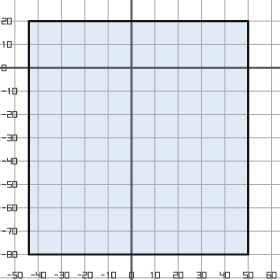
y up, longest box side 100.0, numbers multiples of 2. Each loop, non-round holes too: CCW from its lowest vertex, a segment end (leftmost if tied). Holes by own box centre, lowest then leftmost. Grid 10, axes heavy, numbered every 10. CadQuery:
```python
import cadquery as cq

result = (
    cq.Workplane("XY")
    .moveTo(-44.0, -80.0)
    .lineTo(50.0, -80.0)
    .lineTo(50.0, 20.0)
    .lineTo(-44.0, 20.0)
    .close()
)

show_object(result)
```